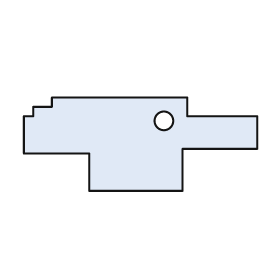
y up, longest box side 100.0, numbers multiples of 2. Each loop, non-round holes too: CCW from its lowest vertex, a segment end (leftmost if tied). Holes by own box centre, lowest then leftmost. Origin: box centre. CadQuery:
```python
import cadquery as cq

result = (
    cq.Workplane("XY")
    .moveTo(-22.0, -20.0)
    .lineTo(18.0, -20.0)
    .lineTo(18.0, -2.0)
    .lineTo(50.0, -2.0)
    .lineTo(50.0, 12.0)
    .lineTo(20.0, 12.0)
    .lineTo(20.0, 20.0)
    .lineTo(-38.0, 20.0)
    .lineTo(-38.0, 16.0)
    .lineTo(-46.0, 16.0)
    .lineTo(-46.0, 12.0)
    .lineTo(-50.0, 12.0)
    .lineTo(-50.0, -4.0)
    .lineTo(-22.0, -4.0)
    .close()
    .moveTo(10.0, 10.0)
    .circle(4.0)
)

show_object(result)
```